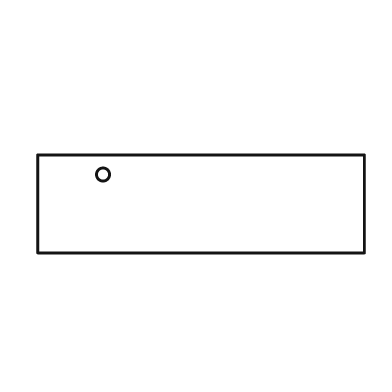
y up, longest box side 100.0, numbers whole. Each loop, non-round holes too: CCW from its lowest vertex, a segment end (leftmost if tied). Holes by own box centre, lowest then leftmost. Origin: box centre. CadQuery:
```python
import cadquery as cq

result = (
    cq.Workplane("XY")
    .moveTo(-50.0, -15.0)
    .lineTo(50.0, -15.0)
    .lineTo(50.0, 15.0)
    .lineTo(-50.0, 15.0)
    .close()
    .moveTo(-30.0, 9.0)
    .circle(2.0)
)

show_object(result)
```